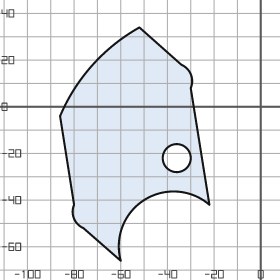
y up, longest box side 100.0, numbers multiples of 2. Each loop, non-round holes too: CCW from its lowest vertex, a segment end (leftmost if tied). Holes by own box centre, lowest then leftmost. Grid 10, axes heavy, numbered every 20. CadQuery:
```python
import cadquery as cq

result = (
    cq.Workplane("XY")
    .moveTo(-60.0, -66.0)
    .threePointArc((-50.0, -40.0), (-22.0, -42.0))
    .lineTo(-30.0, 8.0)
    .threePointArc((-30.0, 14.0), (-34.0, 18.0))
    .lineTo(-52.0, 34.0)
    .threePointArc((-72.0, 18.0), (-86.0, -4.0))
    .lineTo(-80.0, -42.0)
    .threePointArc((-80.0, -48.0), (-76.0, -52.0))
    .close()
    .moveTo(-36.0, -22.0)
    .circle(6.0)
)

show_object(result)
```